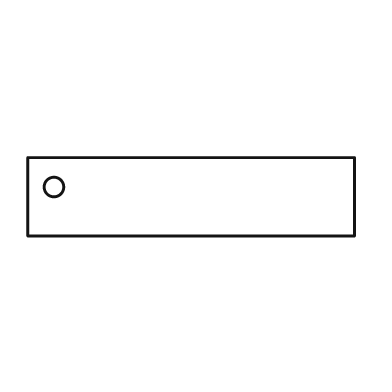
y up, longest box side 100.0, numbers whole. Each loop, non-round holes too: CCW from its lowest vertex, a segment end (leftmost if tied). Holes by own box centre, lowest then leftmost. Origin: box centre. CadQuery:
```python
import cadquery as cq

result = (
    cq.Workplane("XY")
    .moveTo(-50.0, -12.0)
    .lineTo(50.0, -12.0)
    .lineTo(50.0, 12.0)
    .lineTo(-50.0, 12.0)
    .close()
    .moveTo(-42.0, 3.0)
    .circle(3.0)
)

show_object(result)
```